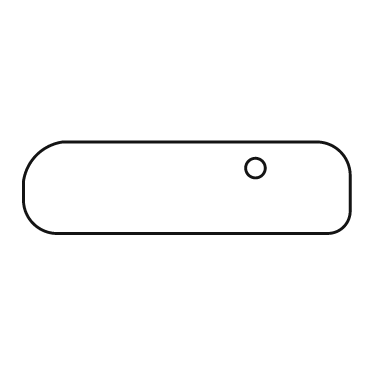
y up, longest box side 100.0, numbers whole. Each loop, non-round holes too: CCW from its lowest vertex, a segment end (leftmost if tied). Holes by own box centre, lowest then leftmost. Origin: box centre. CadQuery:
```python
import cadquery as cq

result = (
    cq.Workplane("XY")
    .moveTo(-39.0, -14.0)
    .lineTo(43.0, -14.0)
    .threePointArc((48.0, -12.0), (50.0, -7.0))
    .lineTo(50.0, 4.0)
    .threePointArc((47.0, 11.0), (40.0, 14.0))
    .lineTo(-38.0, 14.0)
    .threePointArc((-46.0, 10.0), (-50.0, 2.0))
    .lineTo(-50.0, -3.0)
    .threePointArc((-47.0, -11.0), (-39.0, -14.0))
    .close()
    .moveTo(21.0, 6.0)
    .circle(3.0)
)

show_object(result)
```